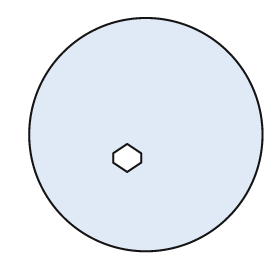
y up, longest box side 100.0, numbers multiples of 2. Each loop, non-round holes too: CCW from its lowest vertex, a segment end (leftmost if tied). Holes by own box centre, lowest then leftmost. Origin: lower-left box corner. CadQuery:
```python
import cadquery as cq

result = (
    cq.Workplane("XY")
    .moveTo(50.0, 50.0)
    .circle(50.0)
    .moveTo(42.0, 34.0)
    .lineTo(48.0, 38.0)
    .lineTo(48.0, 42.0)
    .lineTo(42.0, 46.0)
    .lineTo(36.0, 42.0)
    .lineTo(36.0, 38.0)
    .close()
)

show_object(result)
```